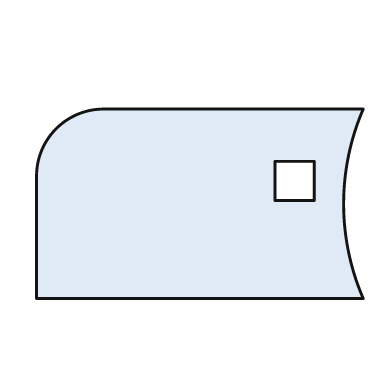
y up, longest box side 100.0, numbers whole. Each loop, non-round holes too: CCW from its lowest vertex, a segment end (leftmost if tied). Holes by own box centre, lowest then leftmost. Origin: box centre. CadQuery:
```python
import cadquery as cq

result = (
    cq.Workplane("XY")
    .moveTo(-50.0, -29.0)
    .lineTo(50.0, -29.0)
    .threePointArc((44.0, 0.0), (50.0, 29.0))
    .lineTo(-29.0, 29.0)
    .threePointArc((-44.0, 23.0), (-50.0, 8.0))
    .close()
    .moveTo(23.0, 1.0)
    .lineTo(35.0, 1.0)
    .lineTo(35.0, 13.0)
    .lineTo(23.0, 13.0)
    .close()
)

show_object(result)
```